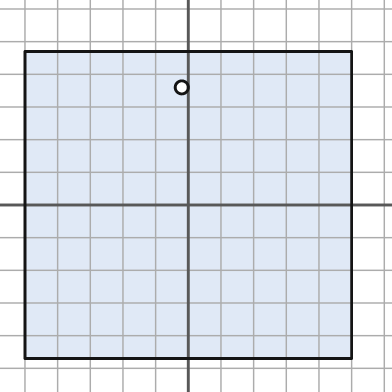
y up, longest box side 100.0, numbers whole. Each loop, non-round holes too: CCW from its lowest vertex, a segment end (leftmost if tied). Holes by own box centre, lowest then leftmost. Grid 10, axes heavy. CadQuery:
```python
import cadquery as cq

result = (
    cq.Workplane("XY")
    .moveTo(-50.0, -47.0)
    .lineTo(50.0, -47.0)
    .lineTo(50.0, 47.0)
    .lineTo(-50.0, 47.0)
    .close()
    .moveTo(-2.0, 36.0)
    .circle(2.0)
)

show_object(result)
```